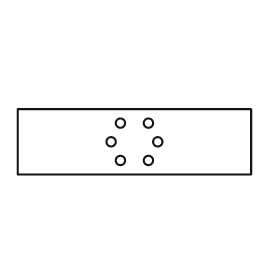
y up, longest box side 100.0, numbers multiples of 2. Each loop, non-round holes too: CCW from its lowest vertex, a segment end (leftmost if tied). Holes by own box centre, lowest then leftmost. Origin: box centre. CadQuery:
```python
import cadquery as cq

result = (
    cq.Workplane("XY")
    .moveTo(-50.0, -14.0)
    .lineTo(50.0, -14.0)
    .lineTo(50.0, 14.0)
    .lineTo(-50.0, 14.0)
    .close()
    .moveTo(-6.0, -8.0)
    .circle(2.0)
    .moveTo(6.0, -8.0)
    .circle(2.0)
    .moveTo(-10.0, 0.0)
    .circle(2.0)
    .moveTo(10.0, 0.0)
    .circle(2.0)
    .moveTo(-6.0, 8.0)
    .circle(2.0)
    .moveTo(6.0, 8.0)
    .circle(2.0)
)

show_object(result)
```